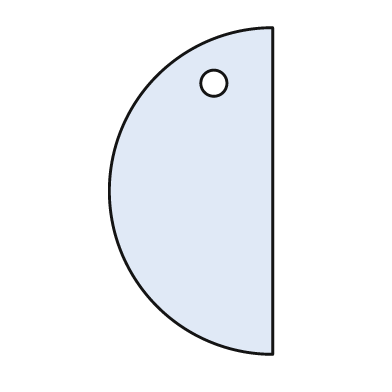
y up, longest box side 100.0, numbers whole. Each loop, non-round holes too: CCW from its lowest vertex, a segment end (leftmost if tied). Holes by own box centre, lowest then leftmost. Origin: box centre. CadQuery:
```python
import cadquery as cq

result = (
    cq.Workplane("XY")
    .moveTo(25.0, -50.0)
    .lineTo(25.0, 50.0)
    .threePointArc((-25.0, 0.0), (25.0, -50.0))
    .close()
    .moveTo(7.0, 33.0)
    .circle(4.0)
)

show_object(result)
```